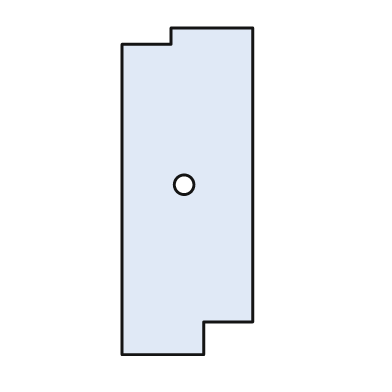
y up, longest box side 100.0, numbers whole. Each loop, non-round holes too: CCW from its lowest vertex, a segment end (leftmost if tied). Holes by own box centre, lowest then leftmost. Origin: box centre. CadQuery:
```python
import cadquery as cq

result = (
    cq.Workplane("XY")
    .moveTo(-20.0, -50.0)
    .lineTo(5.0, -50.0)
    .lineTo(5.0, -40.0)
    .lineTo(20.0, -40.0)
    .lineTo(20.0, 50.0)
    .lineTo(-5.0, 50.0)
    .lineTo(-5.0, 45.0)
    .lineTo(-20.0, 45.0)
    .close()
    .moveTo(-1.0, 2.0)
    .circle(3.0)
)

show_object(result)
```